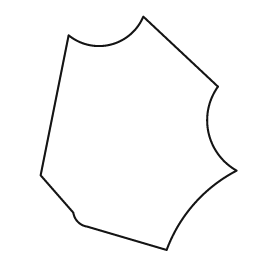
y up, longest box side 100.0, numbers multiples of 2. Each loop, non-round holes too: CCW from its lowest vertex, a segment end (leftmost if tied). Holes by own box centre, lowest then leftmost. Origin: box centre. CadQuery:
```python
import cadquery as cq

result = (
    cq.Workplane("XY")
    .moveTo(12.0, -50.0)
    .threePointArc((24.0, -30.0), (42.0, -16.0))
    .threePointArc((30.0, 0.0), (34.0, 20.0))
    .lineTo(2.0, 50.0)
    .threePointArc((-12.0, 38.0), (-30.0, 42.0))
    .lineTo(-42.0, -18.0)
    .lineTo(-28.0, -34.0)
    .threePointArc((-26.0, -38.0), (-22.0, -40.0))
    .close()
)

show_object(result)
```